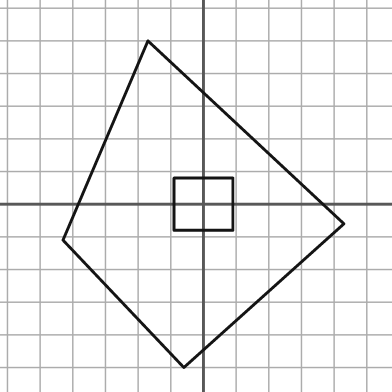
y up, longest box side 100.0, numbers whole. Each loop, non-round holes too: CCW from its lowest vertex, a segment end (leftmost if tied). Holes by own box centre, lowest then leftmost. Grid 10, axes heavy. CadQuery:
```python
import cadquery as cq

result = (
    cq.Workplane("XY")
    .moveTo(-6.0, -50.0)
    .lineTo(43.0, -6.0)
    .lineTo(-17.0, 50.0)
    .lineTo(-43.0, -11.0)
    .close()
    .moveTo(-9.0, -8.0)
    .lineTo(9.0, -8.0)
    .lineTo(9.0, 8.0)
    .lineTo(-9.0, 8.0)
    .close()
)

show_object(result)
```